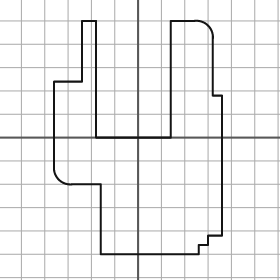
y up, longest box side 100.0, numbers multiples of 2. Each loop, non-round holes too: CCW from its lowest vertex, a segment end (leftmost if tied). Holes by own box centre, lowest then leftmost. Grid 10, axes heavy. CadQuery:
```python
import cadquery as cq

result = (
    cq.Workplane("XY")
    .moveTo(-16.0, -50.0)
    .lineTo(26.0, -50.0)
    .lineTo(26.0, -46.0)
    .lineTo(30.0, -46.0)
    .lineTo(30.0, -42.0)
    .lineTo(36.0, -42.0)
    .lineTo(36.0, 18.0)
    .lineTo(32.0, 18.0)
    .lineTo(32.0, 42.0)
    .threePointArc((30.0, 48.0), (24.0, 50.0))
    .lineTo(14.0, 50.0)
    .lineTo(14.0, 0.0)
    .lineTo(-18.0, 0.0)
    .lineTo(-18.0, 50.0)
    .lineTo(-24.0, 50.0)
    .lineTo(-24.0, 24.0)
    .lineTo(-36.0, 24.0)
    .lineTo(-36.0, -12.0)
    .threePointArc((-34.0, -18.0), (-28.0, -20.0))
    .lineTo(-16.0, -20.0)
    .close()
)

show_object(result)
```